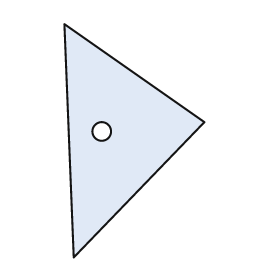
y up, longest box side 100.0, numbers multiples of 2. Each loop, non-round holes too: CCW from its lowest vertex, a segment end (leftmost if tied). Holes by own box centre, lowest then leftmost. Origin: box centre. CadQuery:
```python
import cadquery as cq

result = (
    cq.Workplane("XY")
    .moveTo(-26.0, -50.0)
    .lineTo(30.0, 8.0)
    .lineTo(-30.0, 50.0)
    .close()
    .moveTo(-14.0, 4.0)
    .circle(4.0)
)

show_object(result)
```